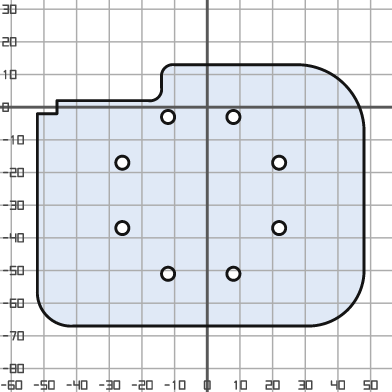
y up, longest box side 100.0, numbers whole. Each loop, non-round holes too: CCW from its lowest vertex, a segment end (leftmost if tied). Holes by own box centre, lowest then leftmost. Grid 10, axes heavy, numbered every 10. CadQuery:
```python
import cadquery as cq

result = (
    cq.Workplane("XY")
    .moveTo(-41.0, -67.0)
    .lineTo(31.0, -67.0)
    .threePointArc((43.0, -62.0), (48.0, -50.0))
    .lineTo(48.0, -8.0)
    .threePointArc((42.0, 7.0), (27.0, 13.0))
    .lineTo(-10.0, 13.0)
    .threePointArc((-13.0, 12.0), (-14.0, 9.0))
    .lineTo(-14.0, 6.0)
    .threePointArc((-15.0, 3.0), (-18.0, 2.0))
    .lineTo(-46.0, 2.0)
    .lineTo(-46.0, -2.0)
    .lineTo(-52.0, -2.0)
    .lineTo(-52.0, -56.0)
    .threePointArc((-49.0, -64.0), (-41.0, -67.0))
    .close()
    .moveTo(-12.0, -51.0)
    .circle(2.0)
    .moveTo(8.0, -51.0)
    .circle(2.0)
    .moveTo(-26.0, -37.0)
    .circle(2.0)
    .moveTo(22.0, -37.0)
    .circle(2.0)
    .moveTo(-26.0, -17.0)
    .circle(2.0)
    .moveTo(22.0, -17.0)
    .circle(2.0)
    .moveTo(-12.0, -3.0)
    .circle(2.0)
    .moveTo(8.0, -3.0)
    .circle(2.0)
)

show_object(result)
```